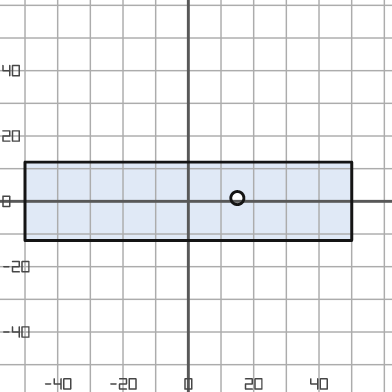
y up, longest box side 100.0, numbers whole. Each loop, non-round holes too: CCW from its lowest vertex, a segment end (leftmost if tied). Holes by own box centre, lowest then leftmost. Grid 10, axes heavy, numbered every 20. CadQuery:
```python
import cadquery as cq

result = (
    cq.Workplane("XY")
    .moveTo(-50.0, -12.0)
    .lineTo(50.0, -12.0)
    .lineTo(50.0, 12.0)
    .lineTo(-50.0, 12.0)
    .close()
    .moveTo(15.0, 1.0)
    .circle(2.0)
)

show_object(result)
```